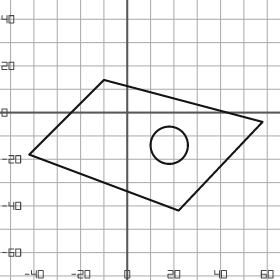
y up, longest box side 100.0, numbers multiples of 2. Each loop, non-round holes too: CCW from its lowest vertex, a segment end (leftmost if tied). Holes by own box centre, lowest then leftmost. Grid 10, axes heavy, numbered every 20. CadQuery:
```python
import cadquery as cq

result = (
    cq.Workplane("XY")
    .moveTo(22.0, -42.0)
    .lineTo(58.0, -4.0)
    .lineTo(-10.0, 14.0)
    .lineTo(-42.0, -18.0)
    .close()
    .moveTo(18.0, -14.0)
    .circle(8.0)
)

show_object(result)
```